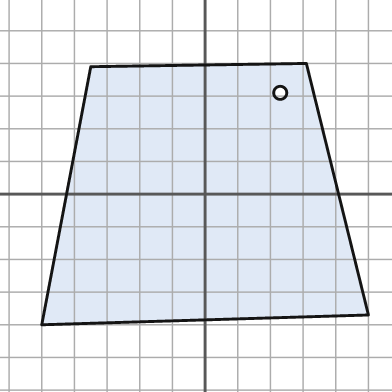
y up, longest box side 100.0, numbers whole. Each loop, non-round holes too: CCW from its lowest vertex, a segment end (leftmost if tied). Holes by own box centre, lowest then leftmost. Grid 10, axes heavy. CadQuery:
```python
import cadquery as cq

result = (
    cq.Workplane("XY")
    .moveTo(-50.0, -40.0)
    .lineTo(50.0, -37.0)
    .lineTo(31.0, 40.0)
    .lineTo(-35.0, 39.0)
    .close()
    .moveTo(23.0, 31.0)
    .circle(2.0)
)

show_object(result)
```